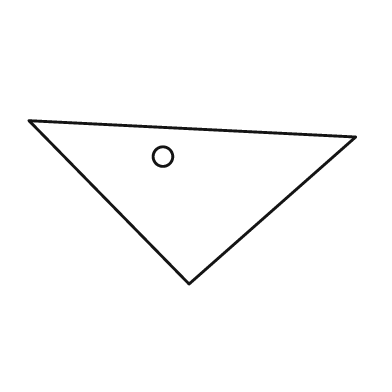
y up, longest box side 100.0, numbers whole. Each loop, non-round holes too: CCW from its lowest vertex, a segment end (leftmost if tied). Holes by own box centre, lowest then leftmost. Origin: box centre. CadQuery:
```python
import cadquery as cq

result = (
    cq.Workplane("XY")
    .moveTo(-1.0, -25.0)
    .lineTo(50.0, 20.0)
    .lineTo(-50.0, 25.0)
    .close()
    .moveTo(-9.0, 14.0)
    .circle(3.0)
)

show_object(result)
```